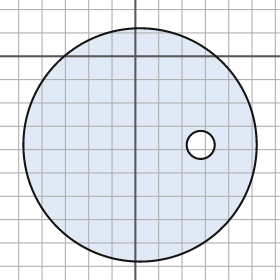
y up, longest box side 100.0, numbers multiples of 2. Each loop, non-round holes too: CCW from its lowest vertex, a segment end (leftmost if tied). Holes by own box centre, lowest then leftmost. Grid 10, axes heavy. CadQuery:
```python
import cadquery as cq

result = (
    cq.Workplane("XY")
    .moveTo(2.0, -38.0)
    .circle(50.0)
    .moveTo(28.0, -38.0)
    .circle(6.0)
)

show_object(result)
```